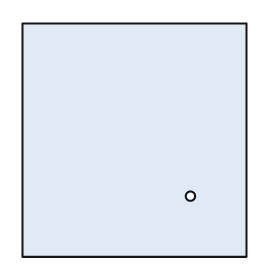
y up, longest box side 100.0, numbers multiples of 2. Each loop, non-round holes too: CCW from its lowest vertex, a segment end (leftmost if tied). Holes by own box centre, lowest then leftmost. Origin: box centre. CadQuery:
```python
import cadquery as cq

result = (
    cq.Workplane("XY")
    .moveTo(-48.0, -50.0)
    .lineTo(48.0, -50.0)
    .lineTo(48.0, 50.0)
    .lineTo(-48.0, 50.0)
    .close()
    .moveTo(24.0, -24.0)
    .circle(2.0)
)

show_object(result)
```